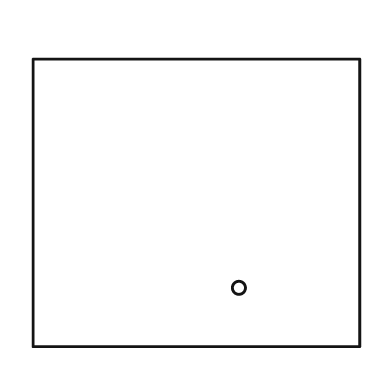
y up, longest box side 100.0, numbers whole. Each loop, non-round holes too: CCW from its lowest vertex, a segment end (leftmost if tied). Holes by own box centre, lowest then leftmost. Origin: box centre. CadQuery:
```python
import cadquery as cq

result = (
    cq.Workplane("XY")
    .moveTo(-50.0, -44.0)
    .lineTo(50.0, -44.0)
    .lineTo(50.0, 44.0)
    .lineTo(-50.0, 44.0)
    .close()
    .moveTo(13.0, -26.0)
    .circle(2.0)
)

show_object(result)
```